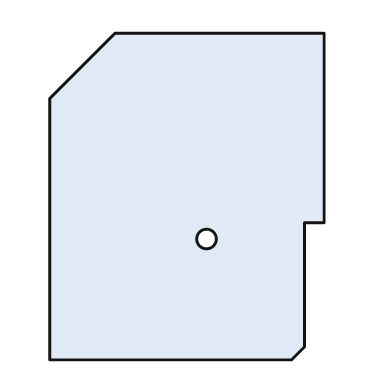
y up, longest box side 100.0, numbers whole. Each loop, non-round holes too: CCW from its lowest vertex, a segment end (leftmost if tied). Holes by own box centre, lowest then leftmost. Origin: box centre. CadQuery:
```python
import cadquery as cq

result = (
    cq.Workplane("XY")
    .moveTo(-42.0, -50.0)
    .lineTo(32.0, -50.0)
    .lineTo(36.0, -46.0)
    .lineTo(36.0, -8.0)
    .lineTo(42.0, -8.0)
    .lineTo(42.0, 50.0)
    .lineTo(-22.0, 50.0)
    .lineTo(-42.0, 30.0)
    .close()
    .moveTo(6.0, -13.0)
    .circle(3.0)
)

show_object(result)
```